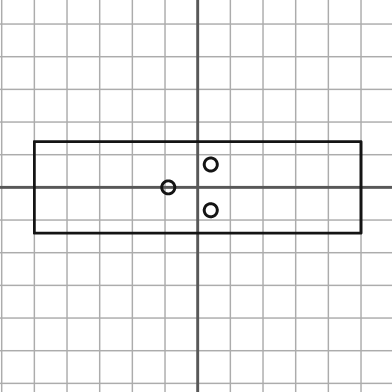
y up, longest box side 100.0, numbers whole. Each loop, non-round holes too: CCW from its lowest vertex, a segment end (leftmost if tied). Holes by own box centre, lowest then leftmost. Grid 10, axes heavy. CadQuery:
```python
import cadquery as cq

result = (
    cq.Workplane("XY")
    .moveTo(-50.0, -14.0)
    .lineTo(50.0, -14.0)
    .lineTo(50.0, 14.0)
    .lineTo(-50.0, 14.0)
    .close()
    .moveTo(4.0, -7.0)
    .circle(2.0)
    .moveTo(-9.0, 0.0)
    .circle(2.0)
    .moveTo(4.0, 7.0)
    .circle(2.0)
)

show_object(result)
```